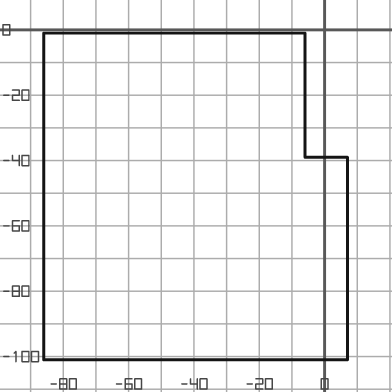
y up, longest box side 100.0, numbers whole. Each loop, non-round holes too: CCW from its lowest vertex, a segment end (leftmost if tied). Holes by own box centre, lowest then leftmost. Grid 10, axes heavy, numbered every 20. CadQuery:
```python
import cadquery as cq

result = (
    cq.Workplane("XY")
    .moveTo(-86.0, -101.0)
    .lineTo(7.0, -101.0)
    .lineTo(7.0, -39.0)
    .lineTo(-6.0, -39.0)
    .lineTo(-6.0, -1.0)
    .lineTo(-86.0, -1.0)
    .close()
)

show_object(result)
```